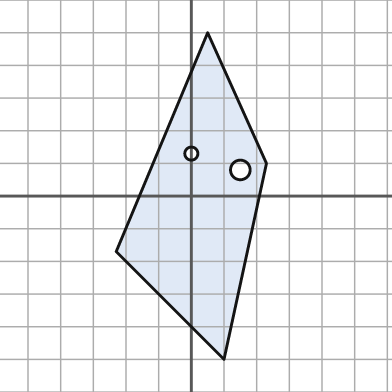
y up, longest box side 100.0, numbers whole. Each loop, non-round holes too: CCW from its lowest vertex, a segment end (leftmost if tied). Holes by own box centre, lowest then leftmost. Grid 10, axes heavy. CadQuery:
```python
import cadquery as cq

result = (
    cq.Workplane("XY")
    .moveTo(10.0, -50.0)
    .lineTo(23.0, 10.0)
    .lineTo(5.0, 50.0)
    .lineTo(-23.0, -17.0)
    .close()
    .moveTo(15.0, 8.0)
    .circle(3.0)
    .moveTo(0.0, 13.0)
    .circle(2.0)
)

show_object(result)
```